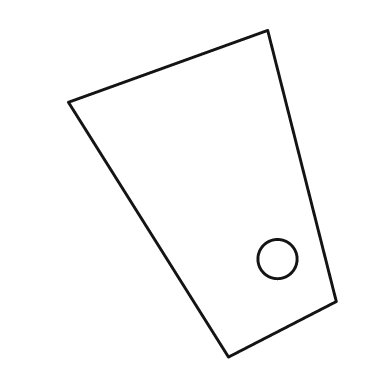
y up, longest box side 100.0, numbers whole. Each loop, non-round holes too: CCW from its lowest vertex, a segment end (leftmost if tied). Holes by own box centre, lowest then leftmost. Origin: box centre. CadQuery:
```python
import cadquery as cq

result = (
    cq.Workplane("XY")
    .moveTo(8.0, -50.0)
    .lineTo(41.0, -33.0)
    .lineTo(20.0, 50.0)
    .lineTo(-41.0, 28.0)
    .close()
    .moveTo(23.0, -20.0)
    .circle(6.0)
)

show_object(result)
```